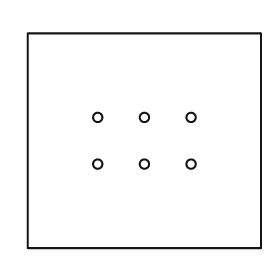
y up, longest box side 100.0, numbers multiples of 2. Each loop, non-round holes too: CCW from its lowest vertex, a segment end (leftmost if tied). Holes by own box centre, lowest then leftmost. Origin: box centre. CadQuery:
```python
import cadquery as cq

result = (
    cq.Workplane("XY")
    .moveTo(-50.0, -46.0)
    .lineTo(50.0, -46.0)
    .lineTo(50.0, 46.0)
    .lineTo(-50.0, 46.0)
    .close()
    .moveTo(-20.0, -10.0)
    .circle(2.0)
    .moveTo(0.0, -10.0)
    .circle(2.0)
    .moveTo(20.0, -10.0)
    .circle(2.0)
    .moveTo(-20.0, 10.0)
    .circle(2.0)
    .moveTo(0.0, 10.0)
    .circle(2.0)
    .moveTo(20.0, 10.0)
    .circle(2.0)
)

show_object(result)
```